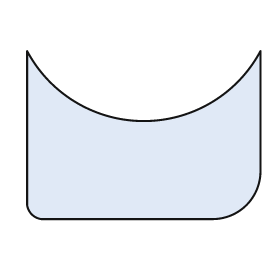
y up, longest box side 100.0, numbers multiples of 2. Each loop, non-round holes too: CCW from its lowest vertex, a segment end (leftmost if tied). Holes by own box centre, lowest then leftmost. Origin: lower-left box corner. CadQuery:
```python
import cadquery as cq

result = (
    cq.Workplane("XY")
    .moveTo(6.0, 0.0)
    .lineTo(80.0, 0.0)
    .threePointArc((94.0, 6.0), (100.0, 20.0))
    .lineTo(100.0, 72.0)
    .threePointArc((50.0, 42.0), (0.0, 72.0))
    .lineTo(0.0, 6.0)
    .threePointArc((2.0, 2.0), (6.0, 0.0))
    .close()
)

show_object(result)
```